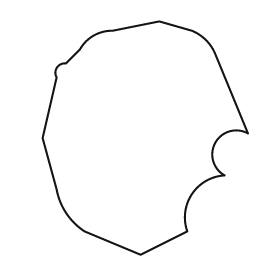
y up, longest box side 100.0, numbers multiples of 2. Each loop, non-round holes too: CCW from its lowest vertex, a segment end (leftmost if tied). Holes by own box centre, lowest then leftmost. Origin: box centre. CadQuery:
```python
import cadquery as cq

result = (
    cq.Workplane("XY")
    .moveTo(-2.0, -50.0)
    .lineTo(18.0, -40.0)
    .threePointArc((20.0, -24.0), (34.0, -16.0))
    .threePointArc((30.0, -2.0), (44.0, 2.0))
    .lineTo(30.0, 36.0)
    .threePointArc((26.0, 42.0), (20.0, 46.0))
    .lineTo(6.0, 50.0)
    .lineTo(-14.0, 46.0)
    .threePointArc((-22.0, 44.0), (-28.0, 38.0))
    .lineTo(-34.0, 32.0)
    .threePointArc((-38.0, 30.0), (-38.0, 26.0))
    .lineTo(-44.0, 0.0)
    .lineTo(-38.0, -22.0)
    .threePointArc((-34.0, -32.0), (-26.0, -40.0))
    .close()
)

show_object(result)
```